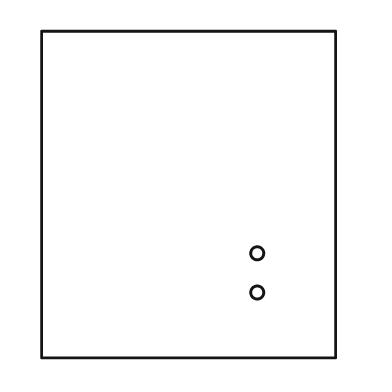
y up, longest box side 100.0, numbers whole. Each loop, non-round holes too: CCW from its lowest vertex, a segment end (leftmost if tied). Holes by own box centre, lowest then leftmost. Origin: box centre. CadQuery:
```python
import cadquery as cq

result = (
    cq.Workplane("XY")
    .moveTo(-45.0, -50.0)
    .lineTo(45.0, -50.0)
    .lineTo(45.0, 50.0)
    .lineTo(-45.0, 50.0)
    .close()
    .moveTo(21.0, -30.0)
    .circle(2.0)
    .moveTo(21.0, -18.0)
    .circle(2.0)
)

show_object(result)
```